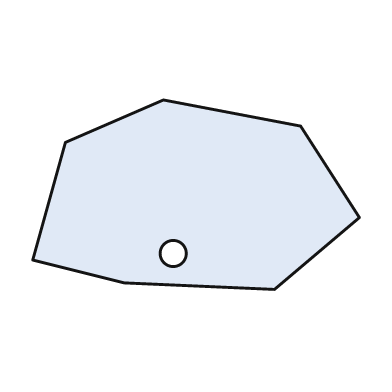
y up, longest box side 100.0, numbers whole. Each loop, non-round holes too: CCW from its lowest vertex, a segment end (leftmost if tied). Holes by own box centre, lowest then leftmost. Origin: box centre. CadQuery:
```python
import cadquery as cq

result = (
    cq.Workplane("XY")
    .moveTo(24.0, -29.0)
    .lineTo(50.0, -7.0)
    .lineTo(32.0, 21.0)
    .lineTo(-10.0, 29.0)
    .lineTo(-40.0, 16.0)
    .lineTo(-50.0, -20.0)
    .lineTo(-22.0, -27.0)
    .close()
    .moveTo(-7.0, -18.0)
    .circle(4.0)
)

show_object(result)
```